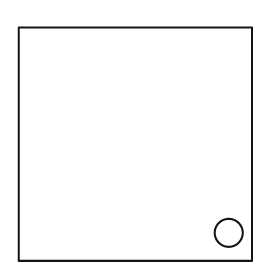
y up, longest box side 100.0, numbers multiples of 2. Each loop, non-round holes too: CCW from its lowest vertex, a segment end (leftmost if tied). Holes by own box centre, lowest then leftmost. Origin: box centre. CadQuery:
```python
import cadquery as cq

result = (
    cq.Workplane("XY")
    .moveTo(-50.0, -50.0)
    .lineTo(50.0, -50.0)
    .lineTo(50.0, 50.0)
    .lineTo(-50.0, 50.0)
    .close()
    .moveTo(40.0, -38.0)
    .circle(6.0)
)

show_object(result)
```